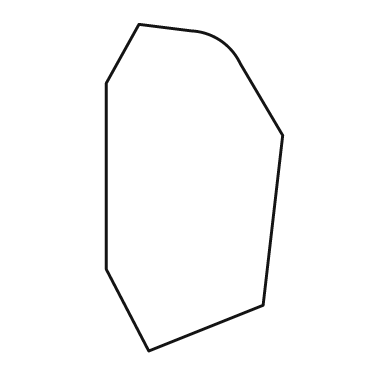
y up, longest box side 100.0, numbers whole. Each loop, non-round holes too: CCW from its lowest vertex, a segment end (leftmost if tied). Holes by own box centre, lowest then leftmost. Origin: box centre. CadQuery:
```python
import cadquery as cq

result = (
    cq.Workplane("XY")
    .moveTo(-14.0, -50.0)
    .lineTo(21.0, -36.0)
    .lineTo(27.0, 16.0)
    .lineTo(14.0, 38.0)
    .threePointArc((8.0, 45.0), (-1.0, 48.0))
    .lineTo(-17.0, 50.0)
    .lineTo(-27.0, 32.0)
    .lineTo(-27.0, -25.0)
    .close()
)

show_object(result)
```